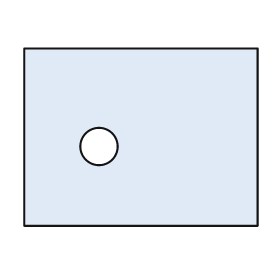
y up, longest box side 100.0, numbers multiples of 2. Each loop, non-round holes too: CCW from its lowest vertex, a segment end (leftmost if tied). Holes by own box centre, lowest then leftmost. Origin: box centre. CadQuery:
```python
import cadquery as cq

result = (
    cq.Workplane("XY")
    .moveTo(-50.0, -38.0)
    .lineTo(50.0, -38.0)
    .lineTo(50.0, 38.0)
    .lineTo(-50.0, 38.0)
    .close()
    .moveTo(-18.0, -4.0)
    .circle(8.0)
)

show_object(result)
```